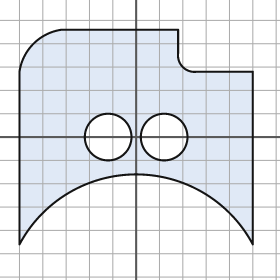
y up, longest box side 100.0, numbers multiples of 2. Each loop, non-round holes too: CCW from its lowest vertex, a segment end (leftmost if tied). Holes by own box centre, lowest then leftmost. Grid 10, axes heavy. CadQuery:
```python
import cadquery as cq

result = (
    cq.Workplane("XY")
    .moveTo(-50.0, -46.0)
    .threePointArc((0.0, -16.0), (50.0, -46.0))
    .lineTo(50.0, 28.0)
    .lineTo(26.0, 28.0)
    .threePointArc((20.0, 30.0), (18.0, 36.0))
    .lineTo(18.0, 46.0)
    .lineTo(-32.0, 46.0)
    .threePointArc((-44.0, 40.0), (-50.0, 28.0))
    .close()
    .moveTo(-12.0, 0.0)
    .circle(10.0)
    .moveTo(12.0, 0.0)
    .circle(10.0)
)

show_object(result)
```